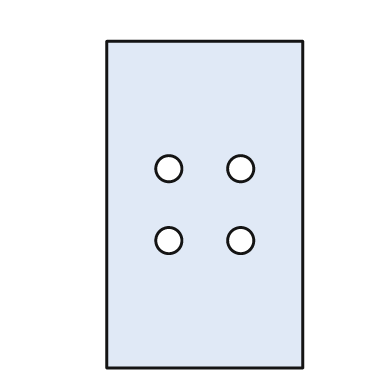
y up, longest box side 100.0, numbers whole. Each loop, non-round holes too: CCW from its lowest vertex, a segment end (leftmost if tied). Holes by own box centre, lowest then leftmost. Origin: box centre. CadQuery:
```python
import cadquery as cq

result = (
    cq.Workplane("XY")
    .moveTo(-30.0, -50.0)
    .lineTo(30.0, -50.0)
    .lineTo(30.0, 50.0)
    .lineTo(-30.0, 50.0)
    .close()
    .moveTo(-11.0, -11.0)
    .circle(4.0)
    .moveTo(11.0, -11.0)
    .circle(4.0)
    .moveTo(-11.0, 11.0)
    .circle(4.0)
    .moveTo(11.0, 11.0)
    .circle(4.0)
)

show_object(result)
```